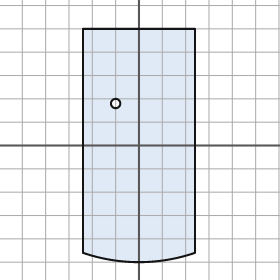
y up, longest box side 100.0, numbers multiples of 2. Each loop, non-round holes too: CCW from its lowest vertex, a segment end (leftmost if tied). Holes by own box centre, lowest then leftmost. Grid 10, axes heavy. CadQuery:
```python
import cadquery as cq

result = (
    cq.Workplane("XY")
    .moveTo(-24.0, -46.0)
    .threePointArc((0.0, -50.0), (24.0, -46.0))
    .lineTo(24.0, 50.0)
    .lineTo(-24.0, 50.0)
    .close()
    .moveTo(-10.0, 18.0)
    .circle(2.0)
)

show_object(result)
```